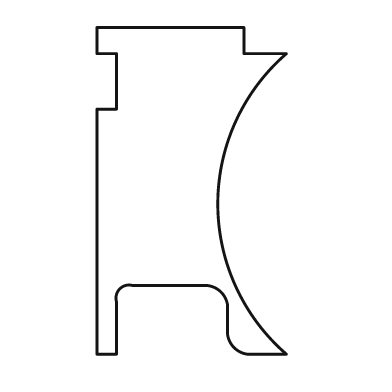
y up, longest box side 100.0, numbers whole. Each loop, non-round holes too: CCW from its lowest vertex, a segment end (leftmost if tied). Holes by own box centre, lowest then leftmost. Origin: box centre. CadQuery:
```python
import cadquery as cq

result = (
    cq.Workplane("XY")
    .moveTo(-29.0, -50.0)
    .lineTo(-23.0, -50.0)
    .lineTo(-23.0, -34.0)
    .threePointArc((-22.0, -30.0), (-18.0, -29.0))
    .lineTo(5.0, -29.0)
    .threePointArc((9.0, -31.0), (11.0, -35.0))
    .lineTo(11.0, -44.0)
    .threePointArc((13.0, -48.0), (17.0, -50.0))
    .lineTo(29.0, -50.0)
    .threePointArc((8.0, -4.0), (29.0, 42.0))
    .lineTo(16.0, 42.0)
    .lineTo(16.0, 50.0)
    .lineTo(-29.0, 50.0)
    .lineTo(-29.0, 42.0)
    .lineTo(-23.0, 42.0)
    .lineTo(-23.0, 25.0)
    .lineTo(-29.0, 25.0)
    .close()
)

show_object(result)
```